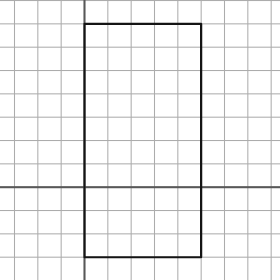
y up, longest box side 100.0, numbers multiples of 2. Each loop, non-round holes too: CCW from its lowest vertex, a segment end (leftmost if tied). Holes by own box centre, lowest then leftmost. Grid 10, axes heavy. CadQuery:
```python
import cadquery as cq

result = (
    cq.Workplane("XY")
    .moveTo(0.0, -30.0)
    .lineTo(50.0, -30.0)
    .lineTo(50.0, 70.0)
    .lineTo(0.0, 70.0)
    .close()
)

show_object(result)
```